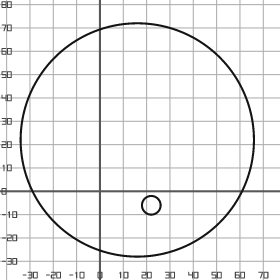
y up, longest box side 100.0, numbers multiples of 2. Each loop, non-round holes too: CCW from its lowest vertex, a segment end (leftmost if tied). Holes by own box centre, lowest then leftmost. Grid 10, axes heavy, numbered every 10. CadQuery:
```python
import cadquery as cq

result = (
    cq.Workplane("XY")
    .moveTo(16.0, 22.0)
    .circle(50.0)
    .moveTo(22.0, -6.0)
    .circle(4.0)
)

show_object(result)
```